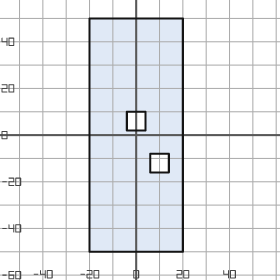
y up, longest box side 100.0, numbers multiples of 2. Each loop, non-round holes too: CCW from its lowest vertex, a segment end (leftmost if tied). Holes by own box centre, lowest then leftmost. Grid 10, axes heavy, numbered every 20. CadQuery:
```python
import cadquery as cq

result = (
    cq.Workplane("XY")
    .moveTo(-20.0, -50.0)
    .lineTo(20.0, -50.0)
    .lineTo(20.0, 50.0)
    .lineTo(-20.0, 50.0)
    .close()
    .moveTo(6.0, -16.0)
    .lineTo(14.0, -16.0)
    .lineTo(14.0, -8.0)
    .lineTo(6.0, -8.0)
    .close()
    .moveTo(-4.0, 2.0)
    .lineTo(4.0, 2.0)
    .lineTo(4.0, 10.0)
    .lineTo(-4.0, 10.0)
    .close()
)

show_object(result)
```